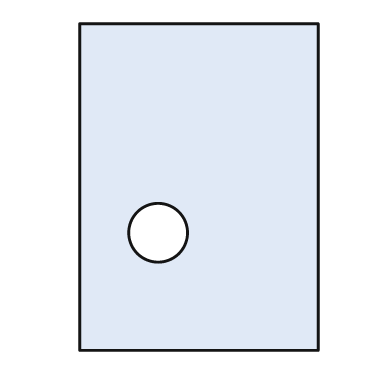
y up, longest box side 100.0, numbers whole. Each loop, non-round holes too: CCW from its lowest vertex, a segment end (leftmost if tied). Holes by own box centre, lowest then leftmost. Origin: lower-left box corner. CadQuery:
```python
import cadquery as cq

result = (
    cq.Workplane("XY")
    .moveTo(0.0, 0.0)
    .lineTo(73.0, 0.0)
    .lineTo(73.0, 100.0)
    .lineTo(0.0, 100.0)
    .close()
    .moveTo(24.0, 36.0)
    .circle(9.0)
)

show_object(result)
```